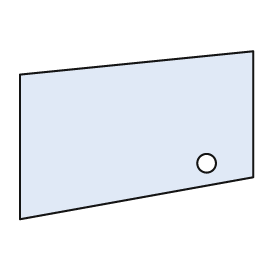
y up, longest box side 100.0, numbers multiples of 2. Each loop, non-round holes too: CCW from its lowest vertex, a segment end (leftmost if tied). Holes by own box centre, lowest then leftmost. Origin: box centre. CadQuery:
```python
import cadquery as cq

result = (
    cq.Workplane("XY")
    .moveTo(-50.0, -36.0)
    .lineTo(50.0, -18.0)
    .lineTo(50.0, 36.0)
    .lineTo(-50.0, 26.0)
    .close()
    .moveTo(30.0, -12.0)
    .circle(4.0)
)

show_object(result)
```